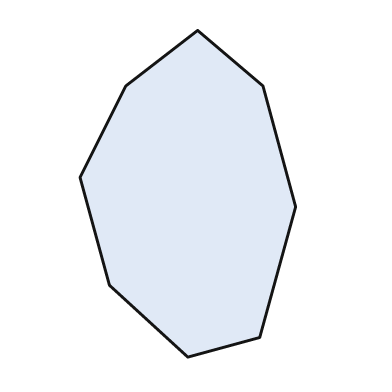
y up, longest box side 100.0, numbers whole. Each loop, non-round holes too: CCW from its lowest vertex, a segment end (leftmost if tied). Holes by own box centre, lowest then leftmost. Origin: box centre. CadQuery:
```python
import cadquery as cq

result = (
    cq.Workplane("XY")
    .moveTo(0.0, -50.0)
    .lineTo(22.0, -44.0)
    .lineTo(33.0, -4.0)
    .lineTo(23.0, 33.0)
    .lineTo(3.0, 50.0)
    .lineTo(-19.0, 33.0)
    .lineTo(-33.0, 5.0)
    .lineTo(-24.0, -28.0)
    .close()
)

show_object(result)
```